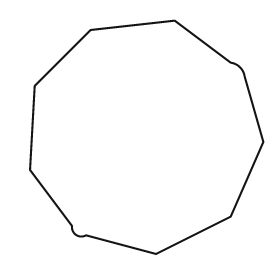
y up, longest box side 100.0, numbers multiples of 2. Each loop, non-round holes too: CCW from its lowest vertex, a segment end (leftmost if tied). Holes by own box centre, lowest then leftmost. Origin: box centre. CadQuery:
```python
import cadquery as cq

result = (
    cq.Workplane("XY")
    .moveTo(4.0, -50.0)
    .lineTo(36.0, -34.0)
    .lineTo(50.0, -2.0)
    .lineTo(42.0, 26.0)
    .threePointArc((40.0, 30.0), (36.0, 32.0))
    .lineTo(12.0, 50.0)
    .lineTo(-24.0, 46.0)
    .lineTo(-48.0, 22.0)
    .lineTo(-50.0, -14.0)
    .lineTo(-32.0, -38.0)
    .threePointArc((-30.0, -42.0), (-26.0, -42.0))
    .close()
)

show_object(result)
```